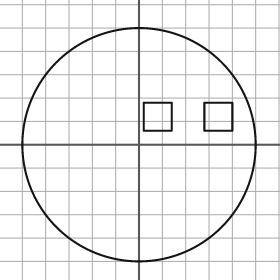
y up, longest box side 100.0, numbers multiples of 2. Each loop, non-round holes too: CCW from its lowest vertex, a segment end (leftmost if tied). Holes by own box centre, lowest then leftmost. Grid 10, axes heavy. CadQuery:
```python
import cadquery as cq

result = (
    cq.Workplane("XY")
    .moveTo(0.0, 0.0)
    .circle(50.0)
    .moveTo(2.0, 6.0)
    .lineTo(14.0, 6.0)
    .lineTo(14.0, 18.0)
    .lineTo(2.0, 18.0)
    .close()
    .moveTo(28.0, 6.0)
    .lineTo(40.0, 6.0)
    .lineTo(40.0, 18.0)
    .lineTo(28.0, 18.0)
    .close()
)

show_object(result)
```